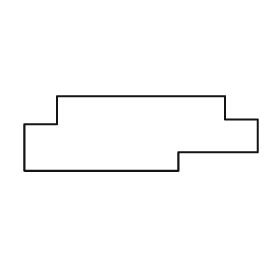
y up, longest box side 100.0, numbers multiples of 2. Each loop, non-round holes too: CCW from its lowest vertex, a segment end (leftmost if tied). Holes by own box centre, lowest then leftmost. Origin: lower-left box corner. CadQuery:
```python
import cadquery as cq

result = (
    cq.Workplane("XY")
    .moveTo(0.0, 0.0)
    .lineTo(66.0, 0.0)
    .lineTo(66.0, 8.0)
    .lineTo(100.0, 8.0)
    .lineTo(100.0, 22.0)
    .lineTo(86.0, 22.0)
    .lineTo(86.0, 32.0)
    .lineTo(14.0, 32.0)
    .lineTo(14.0, 20.0)
    .lineTo(0.0, 20.0)
    .close()
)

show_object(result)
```